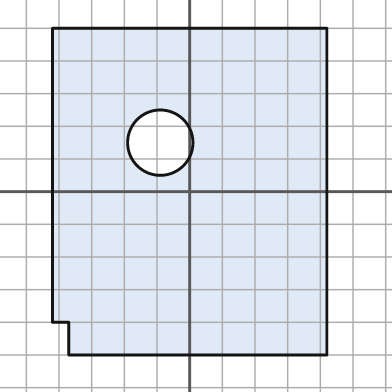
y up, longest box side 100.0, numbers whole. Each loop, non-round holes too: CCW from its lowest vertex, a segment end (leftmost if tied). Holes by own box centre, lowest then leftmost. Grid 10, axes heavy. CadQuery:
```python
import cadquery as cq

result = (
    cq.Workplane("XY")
    .moveTo(-37.0, -50.0)
    .lineTo(42.0, -50.0)
    .lineTo(42.0, 50.0)
    .lineTo(-42.0, 50.0)
    .lineTo(-42.0, -40.0)
    .lineTo(-37.0, -40.0)
    .close()
    .moveTo(-9.0, 15.0)
    .circle(10.0)
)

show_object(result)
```